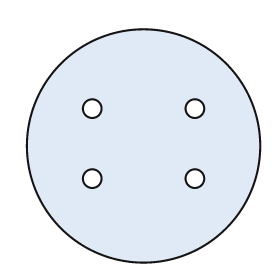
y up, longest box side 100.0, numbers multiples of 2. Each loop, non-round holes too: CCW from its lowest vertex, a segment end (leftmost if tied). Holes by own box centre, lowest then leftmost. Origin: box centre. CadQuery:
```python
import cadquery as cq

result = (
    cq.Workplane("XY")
    .moveTo(0.0, 0.0)
    .circle(50.0)
    .moveTo(-22.0, -14.0)
    .circle(4.0)
    .moveTo(22.0, -14.0)
    .circle(4.0)
    .moveTo(-22.0, 16.0)
    .circle(4.0)
    .moveTo(22.0, 16.0)
    .circle(4.0)
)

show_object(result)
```